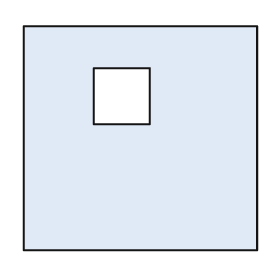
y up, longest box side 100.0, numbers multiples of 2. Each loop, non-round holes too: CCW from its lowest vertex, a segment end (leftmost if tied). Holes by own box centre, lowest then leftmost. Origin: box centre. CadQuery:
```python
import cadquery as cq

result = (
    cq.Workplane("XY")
    .moveTo(-50.0, -48.0)
    .lineTo(50.0, -48.0)
    .lineTo(50.0, 48.0)
    .lineTo(-50.0, 48.0)
    .close()
    .moveTo(-20.0, 6.0)
    .lineTo(4.0, 6.0)
    .lineTo(4.0, 30.0)
    .lineTo(-20.0, 30.0)
    .close()
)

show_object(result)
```